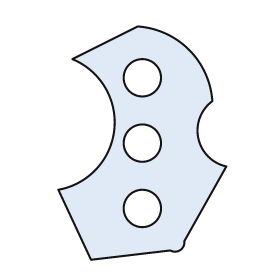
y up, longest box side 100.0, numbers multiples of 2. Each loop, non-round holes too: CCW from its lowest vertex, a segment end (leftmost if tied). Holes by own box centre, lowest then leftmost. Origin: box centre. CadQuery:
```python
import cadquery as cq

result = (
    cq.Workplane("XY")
    .moveTo(-22.0, -50.0)
    .lineTo(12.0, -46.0)
    .threePointArc((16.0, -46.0), (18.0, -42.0))
    .lineTo(36.0, -10.0)
    .threePointArc((24.0, 2.0), (30.0, 18.0))
    .threePointArc((20.0, 40.0), (-2.0, 50.0))
    .lineTo(-30.0, 36.0)
    .threePointArc((-12.0, 6.0), (-36.0, -20.0))
    .close()
    .moveTo(0.0, -28.0)
    .circle(8.0)
    .moveTo(0.0, 0.0)
    .circle(8.0)
    .moveTo(0.0, 28.0)
    .circle(8.0)
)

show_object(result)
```